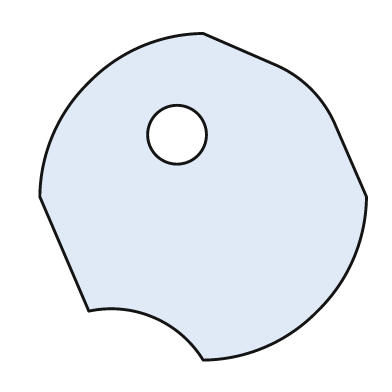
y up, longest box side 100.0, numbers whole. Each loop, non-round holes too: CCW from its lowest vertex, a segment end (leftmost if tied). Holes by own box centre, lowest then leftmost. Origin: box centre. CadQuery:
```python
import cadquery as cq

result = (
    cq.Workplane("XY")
    .moveTo(0.0, -50.0)
    .threePointArc((19.0, -46.0), (35.0, -35.0))
    .threePointArc((46.0, -19.0), (50.0, 0.0))
    .lineTo(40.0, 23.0)
    .threePointArc((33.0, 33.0), (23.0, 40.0))
    .lineTo(0.0, 50.0)
    .threePointArc((-19.0, 46.0), (-35.0, 35.0))
    .threePointArc((-46.0, 19.0), (-50.0, 0.0))
    .lineTo(-35.0, -35.0)
    .threePointArc((-15.0, -37.0), (0.0, -50.0))
    .close()
    .moveTo(-8.0, 19.0)
    .circle(9.0)
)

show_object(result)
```